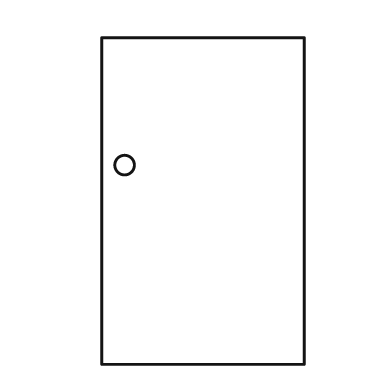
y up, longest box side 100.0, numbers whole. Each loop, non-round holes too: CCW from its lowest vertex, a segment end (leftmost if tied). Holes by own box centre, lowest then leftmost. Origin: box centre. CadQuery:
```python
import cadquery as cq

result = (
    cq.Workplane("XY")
    .moveTo(-31.0, -50.0)
    .lineTo(31.0, -50.0)
    .lineTo(31.0, 50.0)
    .lineTo(-31.0, 50.0)
    .close()
    .moveTo(-24.0, 11.0)
    .circle(3.0)
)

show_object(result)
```